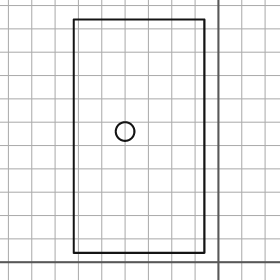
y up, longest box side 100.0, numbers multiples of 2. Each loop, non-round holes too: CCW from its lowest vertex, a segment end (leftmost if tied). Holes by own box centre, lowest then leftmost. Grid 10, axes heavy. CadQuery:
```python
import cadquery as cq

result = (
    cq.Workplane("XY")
    .moveTo(-62.0, 4.0)
    .lineTo(-6.0, 4.0)
    .lineTo(-6.0, 104.0)
    .lineTo(-62.0, 104.0)
    .close()
    .moveTo(-40.0, 56.0)
    .circle(4.0)
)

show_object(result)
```